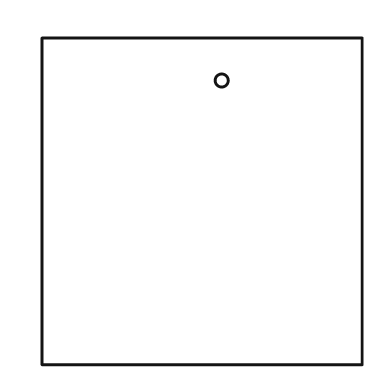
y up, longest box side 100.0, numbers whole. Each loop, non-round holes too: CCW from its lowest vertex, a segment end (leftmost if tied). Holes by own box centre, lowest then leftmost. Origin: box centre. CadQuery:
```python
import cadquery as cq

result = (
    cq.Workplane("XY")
    .moveTo(-49.0, -50.0)
    .lineTo(49.0, -50.0)
    .lineTo(49.0, 50.0)
    .lineTo(-49.0, 50.0)
    .close()
    .moveTo(6.0, 37.0)
    .circle(2.0)
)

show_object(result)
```